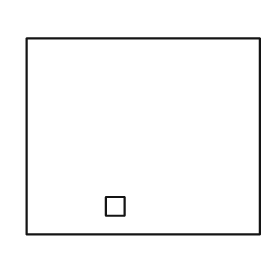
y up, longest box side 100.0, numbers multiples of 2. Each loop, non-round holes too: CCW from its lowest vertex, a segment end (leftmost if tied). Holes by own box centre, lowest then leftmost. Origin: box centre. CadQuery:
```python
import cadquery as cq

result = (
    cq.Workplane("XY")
    .moveTo(-50.0, -42.0)
    .lineTo(50.0, -42.0)
    .lineTo(50.0, 42.0)
    .lineTo(-50.0, 42.0)
    .close()
    .moveTo(-16.0, -34.0)
    .lineTo(-8.0, -34.0)
    .lineTo(-8.0, -26.0)
    .lineTo(-16.0, -26.0)
    .close()
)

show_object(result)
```